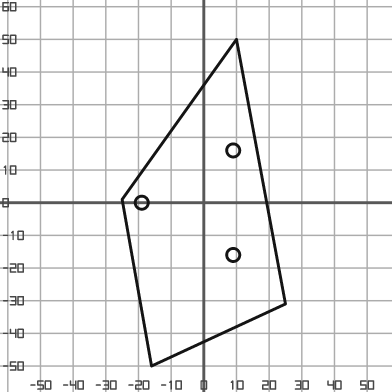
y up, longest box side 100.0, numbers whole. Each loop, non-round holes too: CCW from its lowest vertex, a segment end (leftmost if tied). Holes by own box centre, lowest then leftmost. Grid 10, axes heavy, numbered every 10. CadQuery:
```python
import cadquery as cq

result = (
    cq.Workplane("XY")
    .moveTo(-16.0, -50.0)
    .lineTo(25.0, -31.0)
    .lineTo(10.0, 50.0)
    .lineTo(-25.0, 1.0)
    .close()
    .moveTo(9.0, -16.0)
    .circle(2.0)
    .moveTo(-19.0, 0.0)
    .circle(2.0)
    .moveTo(9.0, 16.0)
    .circle(2.0)
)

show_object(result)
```